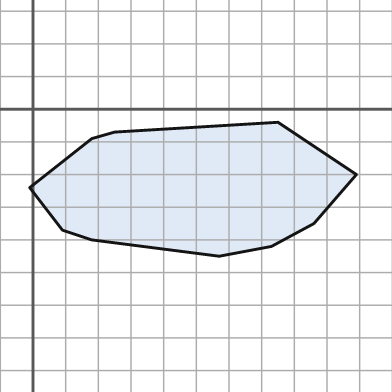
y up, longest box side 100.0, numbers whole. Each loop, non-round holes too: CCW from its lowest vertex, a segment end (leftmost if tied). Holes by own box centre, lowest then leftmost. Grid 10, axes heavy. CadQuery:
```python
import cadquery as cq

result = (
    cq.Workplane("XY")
    .moveTo(57.0, -45.0)
    .lineTo(73.0, -42.0)
    .lineTo(86.0, -35.0)
    .lineTo(99.0, -20.0)
    .lineTo(75.0, -4.0)
    .lineTo(25.0, -7.0)
    .lineTo(18.0, -9.0)
    .lineTo(-1.0, -24.0)
    .lineTo(9.0, -37.0)
    .lineTo(18.0, -40.0)
    .close()
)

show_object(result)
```